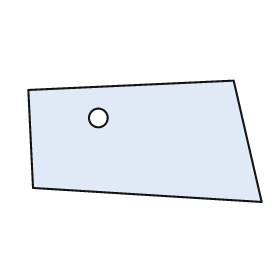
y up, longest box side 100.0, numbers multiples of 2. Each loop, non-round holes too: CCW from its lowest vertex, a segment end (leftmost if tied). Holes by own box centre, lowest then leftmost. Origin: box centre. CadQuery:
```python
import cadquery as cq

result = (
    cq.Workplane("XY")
    .moveTo(50.0, -26.0)
    .lineTo(38.0, 26.0)
    .lineTo(-50.0, 22.0)
    .lineTo(-48.0, -20.0)
    .close()
    .moveTo(-20.0, 10.0)
    .circle(4.0)
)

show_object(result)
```